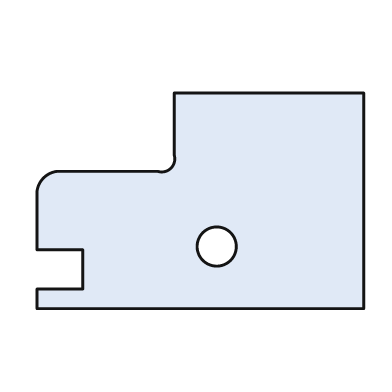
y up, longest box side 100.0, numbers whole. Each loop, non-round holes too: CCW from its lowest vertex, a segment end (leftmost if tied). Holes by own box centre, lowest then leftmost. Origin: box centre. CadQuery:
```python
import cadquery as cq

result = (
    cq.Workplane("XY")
    .moveTo(-50.0, -33.0)
    .lineTo(50.0, -33.0)
    .lineTo(50.0, 33.0)
    .lineTo(-8.0, 33.0)
    .lineTo(-8.0, 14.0)
    .threePointArc((-9.0, 10.0), (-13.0, 9.0))
    .lineTo(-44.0, 9.0)
    .threePointArc((-48.0, 7.0), (-50.0, 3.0))
    .lineTo(-50.0, -15.0)
    .lineTo(-36.0, -15.0)
    .lineTo(-36.0, -27.0)
    .lineTo(-50.0, -27.0)
    .close()
    .moveTo(5.0, -14.0)
    .circle(6.0)
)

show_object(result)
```